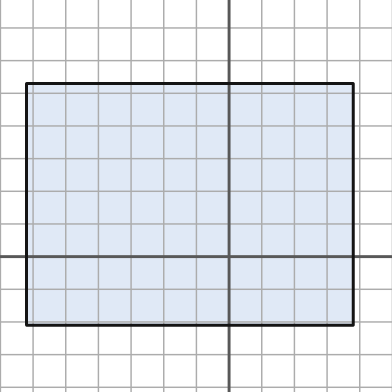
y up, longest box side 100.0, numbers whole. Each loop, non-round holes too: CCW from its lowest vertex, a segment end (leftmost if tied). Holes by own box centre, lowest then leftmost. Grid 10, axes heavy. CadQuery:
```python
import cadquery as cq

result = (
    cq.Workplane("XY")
    .moveTo(-62.0, -21.0)
    .lineTo(38.0, -21.0)
    .lineTo(38.0, 53.0)
    .lineTo(-62.0, 53.0)
    .close()
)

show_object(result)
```